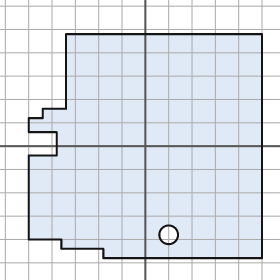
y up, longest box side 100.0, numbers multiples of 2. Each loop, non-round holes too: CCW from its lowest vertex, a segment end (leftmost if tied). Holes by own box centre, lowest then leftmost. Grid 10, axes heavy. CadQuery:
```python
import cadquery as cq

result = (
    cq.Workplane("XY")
    .moveTo(-18.0, -48.0)
    .lineTo(50.0, -48.0)
    .lineTo(50.0, 48.0)
    .lineTo(-34.0, 48.0)
    .lineTo(-34.0, 16.0)
    .lineTo(-44.0, 16.0)
    .lineTo(-44.0, 12.0)
    .lineTo(-50.0, 12.0)
    .lineTo(-50.0, 6.0)
    .lineTo(-38.0, 6.0)
    .lineTo(-38.0, -4.0)
    .lineTo(-50.0, -4.0)
    .lineTo(-50.0, -40.0)
    .lineTo(-36.0, -40.0)
    .lineTo(-36.0, -44.0)
    .lineTo(-18.0, -44.0)
    .close()
    .moveTo(10.0, -38.0)
    .circle(4.0)
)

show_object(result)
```